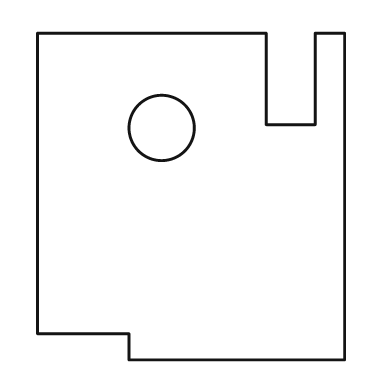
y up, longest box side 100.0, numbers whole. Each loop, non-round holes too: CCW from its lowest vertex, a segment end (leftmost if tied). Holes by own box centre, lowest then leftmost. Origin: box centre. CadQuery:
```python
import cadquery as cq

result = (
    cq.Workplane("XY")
    .moveTo(-19.0, -50.0)
    .lineTo(47.0, -50.0)
    .lineTo(47.0, 50.0)
    .lineTo(38.0, 50.0)
    .lineTo(38.0, 22.0)
    .lineTo(23.0, 22.0)
    .lineTo(23.0, 50.0)
    .lineTo(-47.0, 50.0)
    .lineTo(-47.0, -42.0)
    .lineTo(-19.0, -42.0)
    .close()
    .moveTo(-9.0, 21.0)
    .circle(10.0)
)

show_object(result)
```